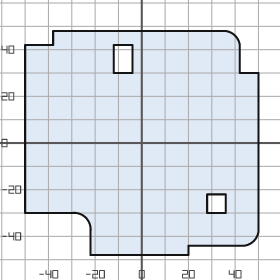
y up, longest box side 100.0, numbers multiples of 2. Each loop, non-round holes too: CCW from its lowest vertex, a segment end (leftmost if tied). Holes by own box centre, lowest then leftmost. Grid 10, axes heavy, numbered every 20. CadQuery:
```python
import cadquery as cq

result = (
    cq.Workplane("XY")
    .moveTo(-22.0, -48.0)
    .lineTo(20.0, -48.0)
    .lineTo(20.0, -44.0)
    .lineTo(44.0, -44.0)
    .threePointArc((48.0, -42.0), (50.0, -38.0))
    .lineTo(50.0, 30.0)
    .lineTo(42.0, 30.0)
    .lineTo(42.0, 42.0)
    .threePointArc((40.0, 46.0), (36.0, 48.0))
    .lineTo(-38.0, 48.0)
    .lineTo(-38.0, 42.0)
    .lineTo(-50.0, 42.0)
    .lineTo(-50.0, -30.0)
    .lineTo(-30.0, -30.0)
    .threePointArc((-24.0, -32.0), (-22.0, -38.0))
    .close()
    .moveTo(28.0, -30.0)
    .lineTo(36.0, -30.0)
    .lineTo(36.0, -22.0)
    .lineTo(28.0, -22.0)
    .close()
    .moveTo(-12.0, 30.0)
    .lineTo(-4.0, 30.0)
    .lineTo(-4.0, 42.0)
    .lineTo(-12.0, 42.0)
    .close()
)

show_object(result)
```